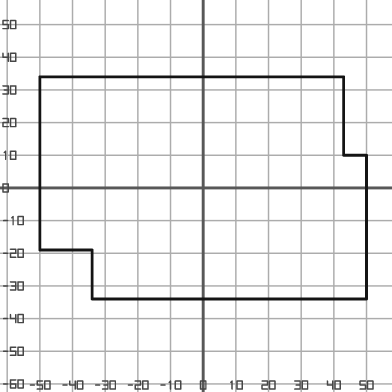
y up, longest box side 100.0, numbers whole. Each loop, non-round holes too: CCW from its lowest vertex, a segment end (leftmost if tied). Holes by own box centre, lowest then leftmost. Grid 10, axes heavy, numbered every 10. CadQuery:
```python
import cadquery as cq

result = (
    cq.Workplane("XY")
    .moveTo(-34.0, -34.0)
    .lineTo(50.0, -34.0)
    .lineTo(50.0, 10.0)
    .lineTo(43.0, 10.0)
    .lineTo(43.0, 34.0)
    .lineTo(-50.0, 34.0)
    .lineTo(-50.0, -19.0)
    .lineTo(-34.0, -19.0)
    .close()
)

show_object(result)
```